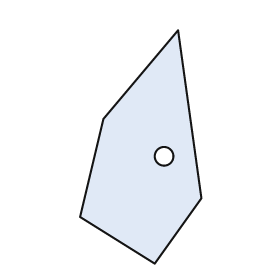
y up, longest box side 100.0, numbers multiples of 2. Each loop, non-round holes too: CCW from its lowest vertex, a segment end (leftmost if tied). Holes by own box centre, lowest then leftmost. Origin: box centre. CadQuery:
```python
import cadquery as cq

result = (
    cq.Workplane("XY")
    .moveTo(6.0, -50.0)
    .lineTo(26.0, -22.0)
    .lineTo(16.0, 50.0)
    .lineTo(-16.0, 12.0)
    .lineTo(-26.0, -30.0)
    .close()
    .moveTo(10.0, -4.0)
    .circle(4.0)
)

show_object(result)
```